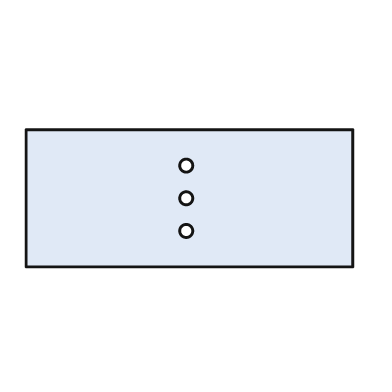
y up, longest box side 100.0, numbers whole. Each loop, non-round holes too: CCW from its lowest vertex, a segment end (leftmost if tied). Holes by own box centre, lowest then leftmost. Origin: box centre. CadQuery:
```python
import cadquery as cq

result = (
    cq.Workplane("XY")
    .moveTo(-50.0, -21.0)
    .lineTo(50.0, -21.0)
    .lineTo(50.0, 21.0)
    .lineTo(-50.0, 21.0)
    .close()
    .moveTo(-1.0, -10.0)
    .circle(2.0)
    .moveTo(-1.0, 0.0)
    .circle(2.0)
    .moveTo(-1.0, 10.0)
    .circle(2.0)
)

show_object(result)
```